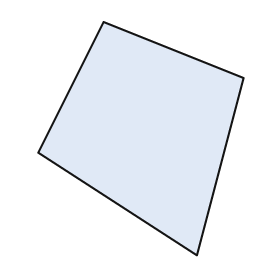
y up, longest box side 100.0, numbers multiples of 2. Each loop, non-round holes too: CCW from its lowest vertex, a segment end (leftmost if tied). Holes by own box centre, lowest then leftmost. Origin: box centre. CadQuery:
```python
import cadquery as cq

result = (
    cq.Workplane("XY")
    .moveTo(24.0, -50.0)
    .lineTo(44.0, 26.0)
    .lineTo(-16.0, 50.0)
    .lineTo(-44.0, -6.0)
    .close()
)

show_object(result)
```